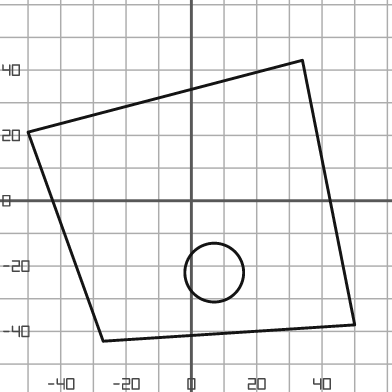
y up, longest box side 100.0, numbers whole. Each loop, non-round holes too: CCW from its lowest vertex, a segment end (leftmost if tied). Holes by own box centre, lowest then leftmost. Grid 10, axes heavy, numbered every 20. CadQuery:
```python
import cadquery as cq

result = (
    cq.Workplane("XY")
    .moveTo(-27.0, -43.0)
    .lineTo(50.0, -38.0)
    .lineTo(34.0, 43.0)
    .lineTo(-50.0, 21.0)
    .close()
    .moveTo(7.0, -22.0)
    .circle(9.0)
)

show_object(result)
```